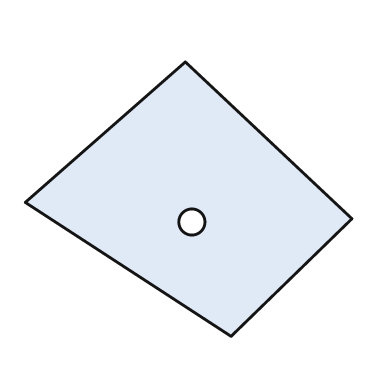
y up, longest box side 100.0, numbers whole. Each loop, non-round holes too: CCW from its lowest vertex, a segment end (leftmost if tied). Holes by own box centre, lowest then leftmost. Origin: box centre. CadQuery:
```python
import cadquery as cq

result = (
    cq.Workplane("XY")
    .moveTo(13.0, -42.0)
    .lineTo(50.0, -6.0)
    .lineTo(-1.0, 42.0)
    .lineTo(-50.0, -1.0)
    .close()
    .moveTo(1.0, -7.0)
    .circle(4.0)
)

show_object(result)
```